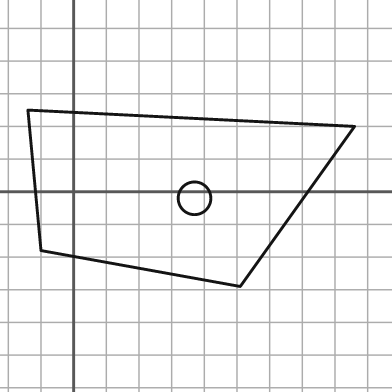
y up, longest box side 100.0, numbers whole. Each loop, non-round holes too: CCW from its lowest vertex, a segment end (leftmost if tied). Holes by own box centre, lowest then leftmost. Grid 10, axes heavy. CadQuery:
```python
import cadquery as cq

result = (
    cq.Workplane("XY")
    .moveTo(51.0, -29.0)
    .lineTo(86.0, 20.0)
    .lineTo(-14.0, 25.0)
    .lineTo(-10.0, -18.0)
    .close()
    .moveTo(37.0, -2.0)
    .circle(5.0)
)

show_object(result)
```